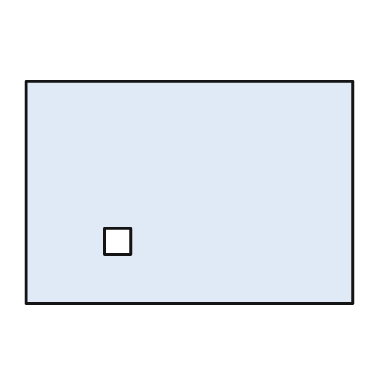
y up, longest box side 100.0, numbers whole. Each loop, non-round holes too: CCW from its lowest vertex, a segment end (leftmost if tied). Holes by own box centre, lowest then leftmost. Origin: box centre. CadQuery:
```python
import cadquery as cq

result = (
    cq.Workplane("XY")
    .moveTo(-50.0, -34.0)
    .lineTo(50.0, -34.0)
    .lineTo(50.0, 34.0)
    .lineTo(-50.0, 34.0)
    .close()
    .moveTo(-26.0, -19.0)
    .lineTo(-18.0, -19.0)
    .lineTo(-18.0, -11.0)
    .lineTo(-26.0, -11.0)
    .close()
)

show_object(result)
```